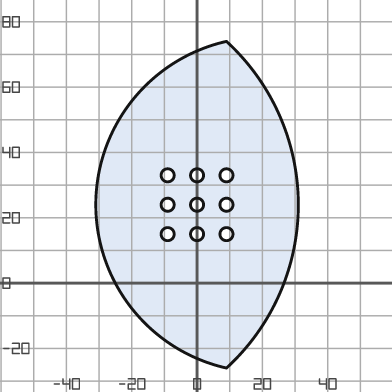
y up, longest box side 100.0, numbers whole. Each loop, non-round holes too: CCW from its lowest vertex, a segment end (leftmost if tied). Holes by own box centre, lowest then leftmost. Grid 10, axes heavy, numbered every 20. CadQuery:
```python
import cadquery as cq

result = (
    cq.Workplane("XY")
    .moveTo(9.0, -26.0)
    .threePointArc((31.0, 24.0), (9.0, 74.0))
    .threePointArc((-31.0, 24.0), (9.0, -26.0))
    .close()
    .moveTo(-9.0, 15.0)
    .circle(2.0)
    .moveTo(0.0, 15.0)
    .circle(2.0)
    .moveTo(9.0, 15.0)
    .circle(2.0)
    .moveTo(-9.0, 24.0)
    .circle(2.0)
    .moveTo(0.0, 24.0)
    .circle(2.0)
    .moveTo(9.0, 24.0)
    .circle(2.0)
    .moveTo(-9.0, 33.0)
    .circle(2.0)
    .moveTo(0.0, 33.0)
    .circle(2.0)
    .moveTo(9.0, 33.0)
    .circle(2.0)
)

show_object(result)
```